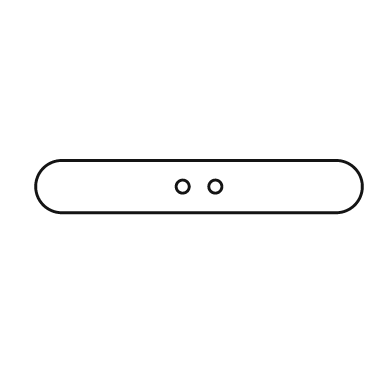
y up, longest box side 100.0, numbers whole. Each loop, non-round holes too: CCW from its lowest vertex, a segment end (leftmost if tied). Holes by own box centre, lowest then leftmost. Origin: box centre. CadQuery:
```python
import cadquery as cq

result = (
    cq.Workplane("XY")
    .moveTo(-42.0, -8.0)
    .lineTo(42.0, -8.0)
    .threePointArc((50.0, 0.0), (42.0, 8.0))
    .lineTo(-42.0, 8.0)
    .threePointArc((-50.0, 0.0), (-42.0, -8.0))
    .close()
    .moveTo(-5.0, 0.0)
    .circle(2.0)
    .moveTo(5.0, 0.0)
    .circle(2.0)
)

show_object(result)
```